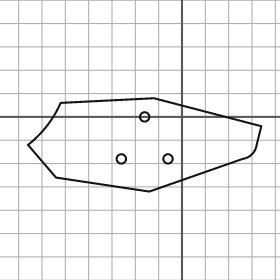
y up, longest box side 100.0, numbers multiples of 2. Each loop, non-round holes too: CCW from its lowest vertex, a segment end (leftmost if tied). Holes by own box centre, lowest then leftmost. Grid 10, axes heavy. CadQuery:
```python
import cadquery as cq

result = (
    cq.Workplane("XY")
    .moveTo(-14.0, -32.0)
    .lineTo(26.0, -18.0)
    .threePointArc((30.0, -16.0), (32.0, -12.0))
    .lineTo(34.0, -4.0)
    .lineTo(-12.0, 8.0)
    .lineTo(-52.0, 6.0)
    .threePointArc((-58.0, -4.0), (-66.0, -12.0))
    .lineTo(-54.0, -26.0)
    .close()
    .moveTo(-26.0, -18.0)
    .circle(2.0)
    .moveTo(-6.0, -18.0)
    .circle(2.0)
    .moveTo(-16.0, 0.0)
    .circle(2.0)
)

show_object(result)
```